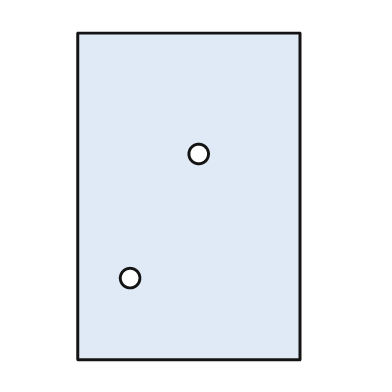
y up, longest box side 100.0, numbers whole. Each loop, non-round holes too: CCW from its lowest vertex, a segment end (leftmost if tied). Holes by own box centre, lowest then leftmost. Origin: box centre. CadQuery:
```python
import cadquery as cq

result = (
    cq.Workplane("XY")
    .moveTo(-34.0, -50.0)
    .lineTo(34.0, -50.0)
    .lineTo(34.0, 50.0)
    .lineTo(-34.0, 50.0)
    .close()
    .moveTo(-18.0, -25.0)
    .circle(3.0)
    .moveTo(3.0, 13.0)
    .circle(3.0)
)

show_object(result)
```